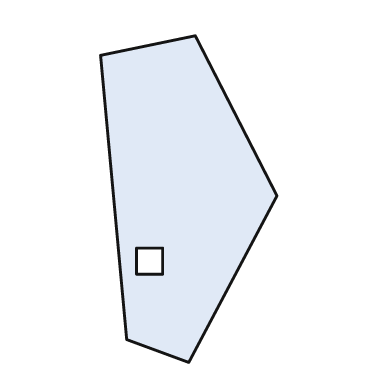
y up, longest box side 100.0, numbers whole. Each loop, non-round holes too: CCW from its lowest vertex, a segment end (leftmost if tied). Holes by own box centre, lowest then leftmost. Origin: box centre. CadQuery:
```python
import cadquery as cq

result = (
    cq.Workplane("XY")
    .moveTo(0.0, -50.0)
    .lineTo(27.0, 1.0)
    .lineTo(2.0, 50.0)
    .lineTo(-27.0, 44.0)
    .lineTo(-19.0, -43.0)
    .close()
    .moveTo(-16.0, -23.0)
    .lineTo(-8.0, -23.0)
    .lineTo(-8.0, -15.0)
    .lineTo(-16.0, -15.0)
    .close()
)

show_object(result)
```